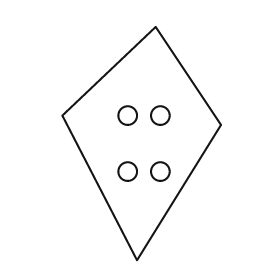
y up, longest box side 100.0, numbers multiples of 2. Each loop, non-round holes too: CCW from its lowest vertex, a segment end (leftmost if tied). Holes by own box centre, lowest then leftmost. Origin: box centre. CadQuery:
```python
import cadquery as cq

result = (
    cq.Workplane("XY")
    .moveTo(-2.0, -50.0)
    .lineTo(34.0, 8.0)
    .lineTo(6.0, 50.0)
    .lineTo(-34.0, 12.0)
    .close()
    .moveTo(-6.0, -12.0)
    .circle(4.0)
    .moveTo(8.0, -12.0)
    .circle(4.0)
    .moveTo(-6.0, 12.0)
    .circle(4.0)
    .moveTo(8.0, 12.0)
    .circle(4.0)
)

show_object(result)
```